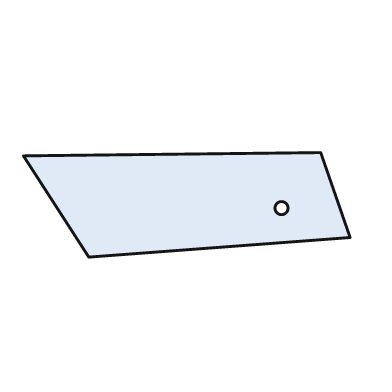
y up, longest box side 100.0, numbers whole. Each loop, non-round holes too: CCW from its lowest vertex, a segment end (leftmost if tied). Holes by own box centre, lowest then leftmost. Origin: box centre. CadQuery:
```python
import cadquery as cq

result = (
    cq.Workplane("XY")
    .moveTo(-30.0, -16.0)
    .lineTo(50.0, -10.0)
    .lineTo(41.0, 16.0)
    .lineTo(-50.0, 15.0)
    .close()
    .moveTo(29.0, -1.0)
    .circle(2.0)
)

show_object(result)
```